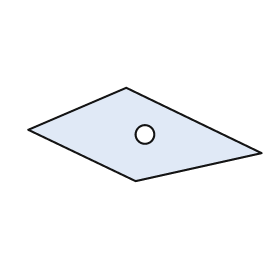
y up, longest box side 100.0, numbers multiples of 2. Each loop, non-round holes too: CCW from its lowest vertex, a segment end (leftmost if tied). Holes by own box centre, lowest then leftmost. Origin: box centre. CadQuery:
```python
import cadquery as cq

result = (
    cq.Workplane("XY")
    .moveTo(-4.0, -20.0)
    .lineTo(50.0, -8.0)
    .lineTo(-8.0, 20.0)
    .lineTo(-50.0, 2.0)
    .close()
    .moveTo(0.0, 0.0)
    .circle(4.0)
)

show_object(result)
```